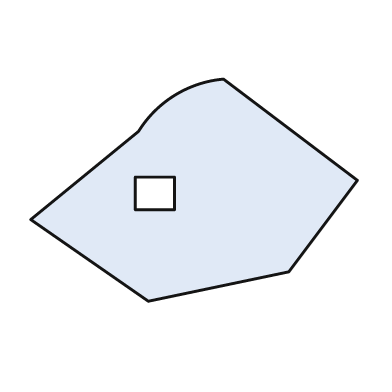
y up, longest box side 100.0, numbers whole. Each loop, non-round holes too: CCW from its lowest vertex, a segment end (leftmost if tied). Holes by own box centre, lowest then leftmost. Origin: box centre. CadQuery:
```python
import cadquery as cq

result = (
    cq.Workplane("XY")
    .moveTo(-14.0, -34.0)
    .lineTo(29.0, -25.0)
    .lineTo(50.0, 3.0)
    .lineTo(9.0, 34.0)
    .threePointArc((-6.0, 29.0), (-17.0, 18.0))
    .lineTo(-50.0, -9.0)
    .close()
    .moveTo(-18.0, -6.0)
    .lineTo(-6.0, -6.0)
    .lineTo(-6.0, 4.0)
    .lineTo(-18.0, 4.0)
    .close()
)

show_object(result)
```